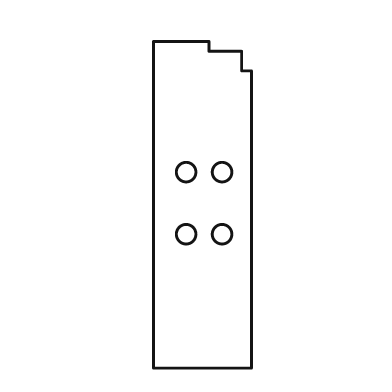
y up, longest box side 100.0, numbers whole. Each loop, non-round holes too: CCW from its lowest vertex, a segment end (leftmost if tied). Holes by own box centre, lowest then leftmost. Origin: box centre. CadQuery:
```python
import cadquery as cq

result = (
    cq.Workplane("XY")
    .moveTo(-15.0, -50.0)
    .lineTo(15.0, -50.0)
    .lineTo(15.0, 41.0)
    .lineTo(12.0, 41.0)
    .lineTo(12.0, 47.0)
    .lineTo(2.0, 47.0)
    .lineTo(2.0, 50.0)
    .lineTo(-15.0, 50.0)
    .close()
    .moveTo(-5.0, -9.0)
    .circle(3.0)
    .moveTo(6.0, -9.0)
    .circle(3.0)
    .moveTo(-5.0, 10.0)
    .circle(3.0)
    .moveTo(6.0, 10.0)
    .circle(3.0)
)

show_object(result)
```